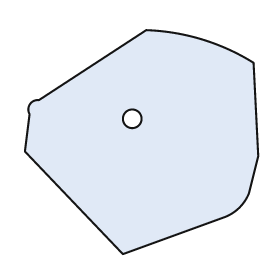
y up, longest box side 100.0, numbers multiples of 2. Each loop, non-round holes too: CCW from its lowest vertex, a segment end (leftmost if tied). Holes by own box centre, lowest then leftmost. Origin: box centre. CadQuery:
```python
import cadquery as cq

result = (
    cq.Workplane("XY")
    .moveTo(-8.0, -48.0)
    .lineTo(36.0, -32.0)
    .threePointArc((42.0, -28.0), (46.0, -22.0))
    .lineTo(50.0, -6.0)
    .lineTo(48.0, 34.0)
    .threePointArc((26.0, 44.0), (2.0, 48.0))
    .lineTo(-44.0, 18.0)
    .threePointArc((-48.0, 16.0), (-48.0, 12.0))
    .lineTo(-50.0, -4.0)
    .close()
    .moveTo(-4.0, 10.0)
    .circle(4.0)
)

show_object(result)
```